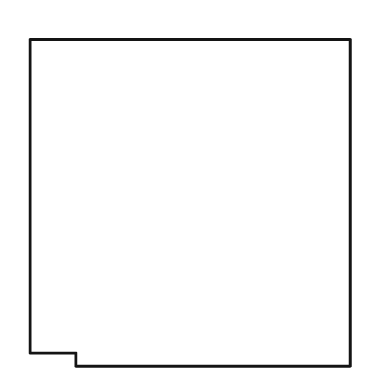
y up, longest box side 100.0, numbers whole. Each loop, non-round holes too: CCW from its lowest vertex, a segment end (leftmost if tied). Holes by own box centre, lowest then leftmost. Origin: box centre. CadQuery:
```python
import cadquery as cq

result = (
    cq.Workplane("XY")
    .moveTo(-35.0, -50.0)
    .lineTo(49.0, -50.0)
    .lineTo(49.0, 50.0)
    .lineTo(-49.0, 50.0)
    .lineTo(-49.0, -46.0)
    .lineTo(-35.0, -46.0)
    .close()
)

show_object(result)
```